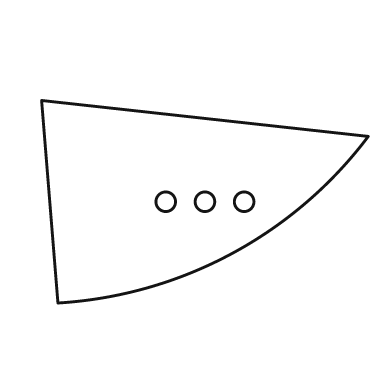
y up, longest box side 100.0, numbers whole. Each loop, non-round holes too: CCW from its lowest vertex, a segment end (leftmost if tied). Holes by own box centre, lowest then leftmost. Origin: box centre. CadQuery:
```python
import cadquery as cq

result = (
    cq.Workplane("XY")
    .moveTo(-45.0, -31.0)
    .threePointArc((8.0, -16.0), (50.0, 20.0))
    .lineTo(-50.0, 31.0)
    .close()
    .moveTo(-12.0, 0.0)
    .circle(3.0)
    .moveTo(0.0, 0.0)
    .circle(3.0)
    .moveTo(12.0, 0.0)
    .circle(3.0)
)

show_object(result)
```